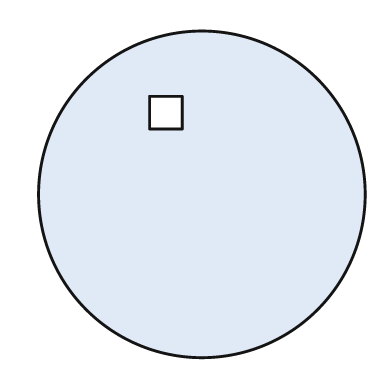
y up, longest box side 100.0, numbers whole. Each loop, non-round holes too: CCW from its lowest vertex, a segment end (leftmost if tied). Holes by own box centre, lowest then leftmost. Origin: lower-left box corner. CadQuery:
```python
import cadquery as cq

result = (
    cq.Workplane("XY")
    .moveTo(50.0, 50.0)
    .circle(50.0)
    .moveTo(34.0, 70.0)
    .lineTo(44.0, 70.0)
    .lineTo(44.0, 80.0)
    .lineTo(34.0, 80.0)
    .close()
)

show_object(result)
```